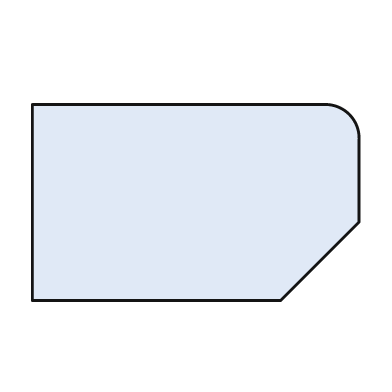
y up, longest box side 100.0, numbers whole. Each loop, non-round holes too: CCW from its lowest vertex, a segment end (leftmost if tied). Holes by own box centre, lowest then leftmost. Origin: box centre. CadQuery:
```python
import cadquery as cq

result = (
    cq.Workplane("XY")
    .moveTo(-50.0, -30.0)
    .lineTo(26.0, -30.0)
    .lineTo(50.0, -6.0)
    .lineTo(50.0, 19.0)
    .threePointArc((47.0, 27.0), (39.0, 30.0))
    .lineTo(-50.0, 30.0)
    .close()
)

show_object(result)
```